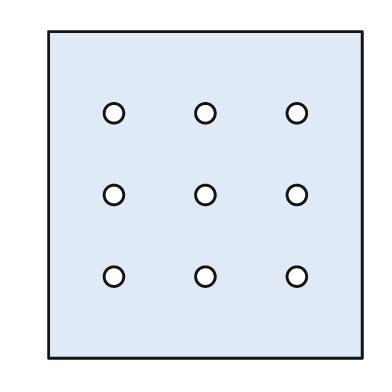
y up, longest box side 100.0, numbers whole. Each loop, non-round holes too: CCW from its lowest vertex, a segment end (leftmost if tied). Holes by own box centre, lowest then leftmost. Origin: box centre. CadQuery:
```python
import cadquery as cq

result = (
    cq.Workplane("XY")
    .moveTo(-48.0, -50.0)
    .lineTo(48.0, -50.0)
    .lineTo(48.0, 50.0)
    .lineTo(-48.0, 50.0)
    .close()
    .moveTo(-28.0, -25.0)
    .circle(3.0)
    .moveTo(0.0, -25.0)
    .circle(3.0)
    .moveTo(28.0, -25.0)
    .circle(3.0)
    .moveTo(-28.0, 0.0)
    .circle(3.0)
    .moveTo(0.0, 0.0)
    .circle(3.0)
    .moveTo(28.0, 0.0)
    .circle(3.0)
    .moveTo(-28.0, 25.0)
    .circle(3.0)
    .moveTo(0.0, 25.0)
    .circle(3.0)
    .moveTo(28.0, 25.0)
    .circle(3.0)
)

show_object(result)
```